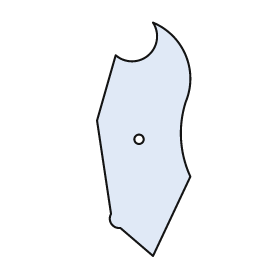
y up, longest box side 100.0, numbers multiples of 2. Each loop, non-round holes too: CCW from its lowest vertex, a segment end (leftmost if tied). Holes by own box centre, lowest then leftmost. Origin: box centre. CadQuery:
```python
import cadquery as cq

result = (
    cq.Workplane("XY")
    .moveTo(4.0, -50.0)
    .lineTo(20.0, -16.0)
    .threePointArc((16.0, 0.0), (18.0, 16.0))
    .threePointArc((18.0, 36.0), (4.0, 50.0))
    .threePointArc((2.0, 36.0), (-12.0, 36.0))
    .lineTo(-20.0, 8.0)
    .lineTo(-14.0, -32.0)
    .threePointArc((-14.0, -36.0), (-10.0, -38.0))
    .close()
    .moveTo(-2.0, 0.0)
    .circle(2.0)
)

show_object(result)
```